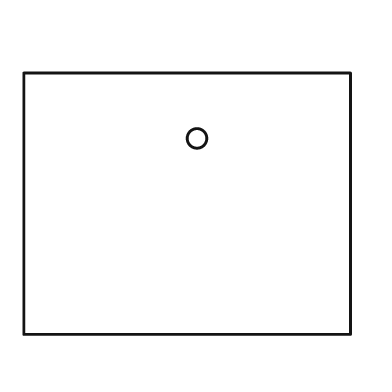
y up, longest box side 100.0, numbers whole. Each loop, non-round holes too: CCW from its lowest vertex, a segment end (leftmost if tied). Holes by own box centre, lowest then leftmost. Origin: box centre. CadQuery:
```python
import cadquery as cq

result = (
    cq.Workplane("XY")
    .moveTo(-50.0, -40.0)
    .lineTo(50.0, -40.0)
    .lineTo(50.0, 40.0)
    .lineTo(-50.0, 40.0)
    .close()
    .moveTo(3.0, 20.0)
    .circle(3.0)
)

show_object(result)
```